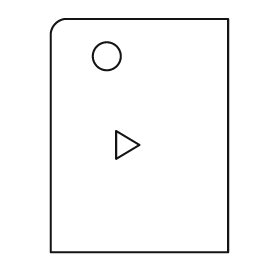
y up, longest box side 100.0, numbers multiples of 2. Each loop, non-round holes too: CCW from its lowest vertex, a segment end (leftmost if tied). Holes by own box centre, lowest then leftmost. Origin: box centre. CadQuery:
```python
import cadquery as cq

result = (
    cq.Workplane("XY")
    .moveTo(-38.0, -50.0)
    .lineTo(38.0, -50.0)
    .lineTo(38.0, 50.0)
    .lineTo(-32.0, 50.0)
    .threePointArc((-36.0, 48.0), (-38.0, 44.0))
    .close()
    .moveTo(-10.0, -10.0)
    .lineTo(0.0, -4.0)
    .lineTo(-10.0, 2.0)
    .close()
    .moveTo(-14.0, 34.0)
    .circle(6.0)
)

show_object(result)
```